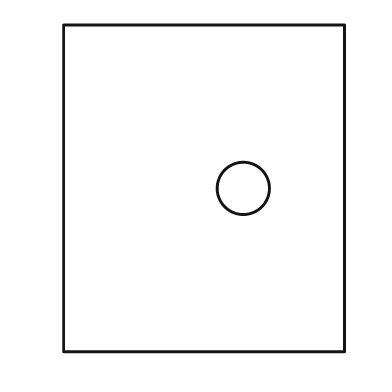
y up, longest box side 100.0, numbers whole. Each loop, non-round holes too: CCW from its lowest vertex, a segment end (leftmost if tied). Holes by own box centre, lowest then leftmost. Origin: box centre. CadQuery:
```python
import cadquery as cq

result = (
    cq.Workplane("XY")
    .moveTo(-43.0, -50.0)
    .lineTo(43.0, -50.0)
    .lineTo(43.0, 50.0)
    .lineTo(-43.0, 50.0)
    .close()
    .moveTo(12.0, 0.0)
    .circle(8.0)
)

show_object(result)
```